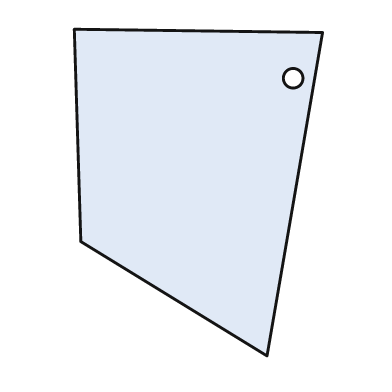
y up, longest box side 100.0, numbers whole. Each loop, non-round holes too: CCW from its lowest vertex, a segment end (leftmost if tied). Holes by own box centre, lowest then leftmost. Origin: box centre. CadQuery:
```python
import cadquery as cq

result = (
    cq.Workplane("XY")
    .moveTo(21.0, -50.0)
    .lineTo(38.0, 49.0)
    .lineTo(-38.0, 50.0)
    .lineTo(-36.0, -15.0)
    .close()
    .moveTo(29.0, 35.0)
    .circle(3.0)
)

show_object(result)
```